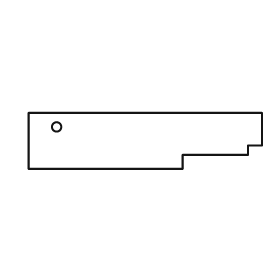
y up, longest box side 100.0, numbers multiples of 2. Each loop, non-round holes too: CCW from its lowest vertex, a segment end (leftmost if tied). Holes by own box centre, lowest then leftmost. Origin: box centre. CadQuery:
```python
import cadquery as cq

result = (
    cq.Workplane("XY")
    .moveTo(-50.0, -12.0)
    .lineTo(16.0, -12.0)
    .lineTo(16.0, -6.0)
    .lineTo(44.0, -6.0)
    .lineTo(44.0, -2.0)
    .lineTo(50.0, -2.0)
    .lineTo(50.0, 12.0)
    .lineTo(-50.0, 12.0)
    .close()
    .moveTo(-38.0, 6.0)
    .circle(2.0)
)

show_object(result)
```